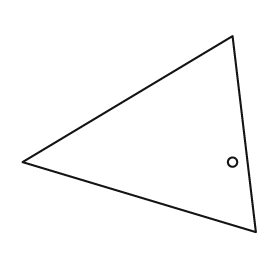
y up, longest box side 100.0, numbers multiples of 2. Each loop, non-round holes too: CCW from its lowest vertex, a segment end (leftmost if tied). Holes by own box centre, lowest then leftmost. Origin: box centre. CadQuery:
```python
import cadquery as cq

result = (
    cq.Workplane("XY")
    .moveTo(50.0, -42.0)
    .lineTo(40.0, 42.0)
    .lineTo(-50.0, -12.0)
    .close()
    .moveTo(40.0, -12.0)
    .circle(2.0)
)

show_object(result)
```